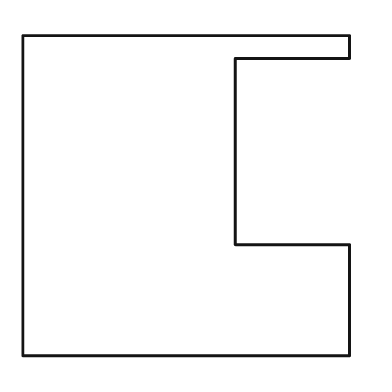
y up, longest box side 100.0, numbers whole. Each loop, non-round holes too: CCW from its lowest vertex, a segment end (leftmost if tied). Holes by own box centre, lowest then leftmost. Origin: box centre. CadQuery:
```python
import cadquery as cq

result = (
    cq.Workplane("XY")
    .moveTo(-50.0, -49.0)
    .lineTo(50.0, -49.0)
    .lineTo(50.0, -15.0)
    .lineTo(15.0, -15.0)
    .lineTo(15.0, 42.0)
    .lineTo(50.0, 42.0)
    .lineTo(50.0, 49.0)
    .lineTo(-50.0, 49.0)
    .close()
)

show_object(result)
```